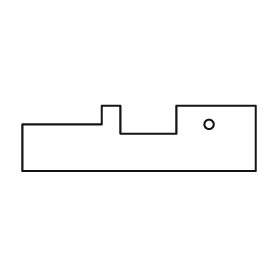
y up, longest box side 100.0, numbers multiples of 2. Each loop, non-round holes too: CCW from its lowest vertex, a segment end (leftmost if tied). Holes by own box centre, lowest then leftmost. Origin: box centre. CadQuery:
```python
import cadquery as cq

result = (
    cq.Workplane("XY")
    .moveTo(-50.0, -14.0)
    .lineTo(50.0, -14.0)
    .lineTo(50.0, 14.0)
    .lineTo(16.0, 14.0)
    .lineTo(16.0, 2.0)
    .lineTo(-8.0, 2.0)
    .lineTo(-8.0, 14.0)
    .lineTo(-16.0, 14.0)
    .lineTo(-16.0, 6.0)
    .lineTo(-50.0, 6.0)
    .close()
    .moveTo(30.0, 6.0)
    .circle(2.0)
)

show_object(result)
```